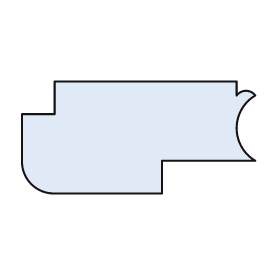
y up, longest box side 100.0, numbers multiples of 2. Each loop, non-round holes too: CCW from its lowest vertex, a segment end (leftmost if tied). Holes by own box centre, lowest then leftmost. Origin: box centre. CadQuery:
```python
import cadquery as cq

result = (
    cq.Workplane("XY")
    .moveTo(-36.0, -24.0)
    .lineTo(10.0, -24.0)
    .lineTo(10.0, -10.0)
    .lineTo(50.0, -10.0)
    .threePointArc((42.0, 4.0), (50.0, 18.0))
    .threePointArc((46.0, 20.0), (42.0, 18.0))
    .lineTo(42.0, 24.0)
    .lineTo(-36.0, 24.0)
    .lineTo(-36.0, 10.0)
    .lineTo(-50.0, 10.0)
    .lineTo(-50.0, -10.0)
    .threePointArc((-46.0, -20.0), (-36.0, -24.0))
    .close()
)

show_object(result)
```